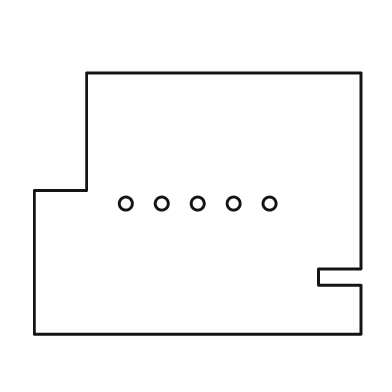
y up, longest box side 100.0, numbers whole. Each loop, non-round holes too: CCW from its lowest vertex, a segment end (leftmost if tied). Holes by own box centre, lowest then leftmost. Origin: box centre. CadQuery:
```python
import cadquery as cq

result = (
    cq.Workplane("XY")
    .moveTo(-50.0, -40.0)
    .lineTo(50.0, -40.0)
    .lineTo(50.0, -25.0)
    .lineTo(37.0, -25.0)
    .lineTo(37.0, -20.0)
    .lineTo(50.0, -20.0)
    .lineTo(50.0, 40.0)
    .lineTo(-34.0, 40.0)
    .lineTo(-34.0, 4.0)
    .lineTo(-50.0, 4.0)
    .close()
    .moveTo(-22.0, 0.0)
    .circle(2.0)
    .moveTo(-11.0, 0.0)
    .circle(2.0)
    .moveTo(0.0, 0.0)
    .circle(2.0)
    .moveTo(11.0, 0.0)
    .circle(2.0)
    .moveTo(22.0, 0.0)
    .circle(2.0)
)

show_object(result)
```